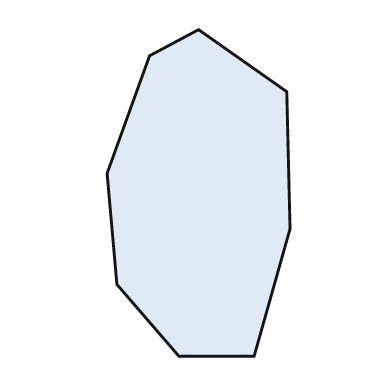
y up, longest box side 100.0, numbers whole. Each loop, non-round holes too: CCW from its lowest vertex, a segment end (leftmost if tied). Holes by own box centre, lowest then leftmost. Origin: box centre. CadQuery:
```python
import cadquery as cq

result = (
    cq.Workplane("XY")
    .moveTo(-6.0, -50.0)
    .lineTo(17.0, -50.0)
    .lineTo(28.0, -11.0)
    .lineTo(27.0, 31.0)
    .lineTo(0.0, 50.0)
    .lineTo(-15.0, 42.0)
    .lineTo(-28.0, 6.0)
    .lineTo(-25.0, -28.0)
    .close()
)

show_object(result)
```